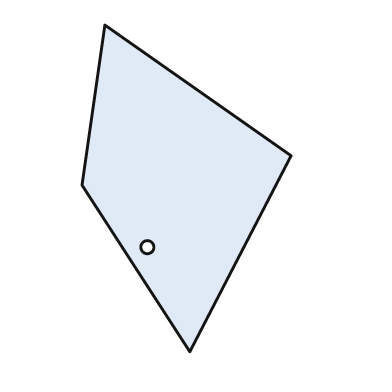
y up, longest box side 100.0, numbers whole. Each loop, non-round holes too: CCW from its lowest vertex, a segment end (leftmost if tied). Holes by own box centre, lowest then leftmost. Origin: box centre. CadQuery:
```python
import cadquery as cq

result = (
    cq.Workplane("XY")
    .moveTo(1.0, -50.0)
    .lineTo(32.0, 10.0)
    .lineTo(-25.0, 50.0)
    .lineTo(-32.0, 1.0)
    .close()
    .moveTo(-12.0, -18.0)
    .circle(2.0)
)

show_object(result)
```